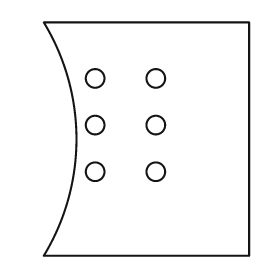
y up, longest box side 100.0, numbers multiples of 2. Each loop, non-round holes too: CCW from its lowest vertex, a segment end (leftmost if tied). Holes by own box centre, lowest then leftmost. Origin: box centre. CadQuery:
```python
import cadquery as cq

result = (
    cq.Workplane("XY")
    .moveTo(-44.0, -50.0)
    .lineTo(44.0, -50.0)
    .lineTo(44.0, 50.0)
    .lineTo(-44.0, 50.0)
    .threePointArc((-30.0, 0.0), (-44.0, -50.0))
    .close()
    .moveTo(-22.0, -14.0)
    .circle(4.0)
    .moveTo(4.0, -14.0)
    .circle(4.0)
    .moveTo(-22.0, 6.0)
    .circle(4.0)
    .moveTo(4.0, 6.0)
    .circle(4.0)
    .moveTo(-22.0, 26.0)
    .circle(4.0)
    .moveTo(4.0, 26.0)
    .circle(4.0)
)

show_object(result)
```